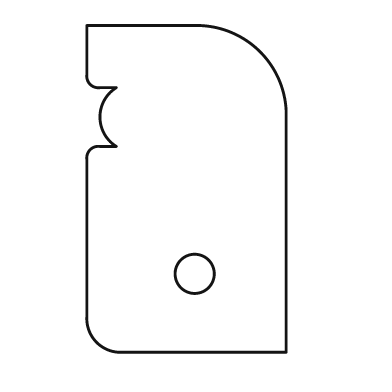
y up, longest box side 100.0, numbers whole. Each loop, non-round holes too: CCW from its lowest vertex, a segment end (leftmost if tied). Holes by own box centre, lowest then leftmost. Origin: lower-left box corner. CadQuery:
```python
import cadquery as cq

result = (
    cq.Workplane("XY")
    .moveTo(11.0, 0.0)
    .lineTo(61.0, 0.0)
    .lineTo(61.0, 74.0)
    .threePointArc((53.0, 92.0), (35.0, 100.0))
    .lineTo(0.0, 100.0)
    .lineTo(0.0, 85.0)
    .threePointArc((1.0, 82.0), (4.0, 81.0))
    .lineTo(9.0, 81.0)
    .threePointArc((4.0, 72.0), (9.0, 63.0))
    .lineTo(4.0, 63.0)
    .threePointArc((1.0, 62.0), (0.0, 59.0))
    .lineTo(0.0, 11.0)
    .threePointArc((3.0, 3.0), (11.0, 0.0))
    .close()
    .moveTo(33.0, 24.0)
    .circle(6.0)
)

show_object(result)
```